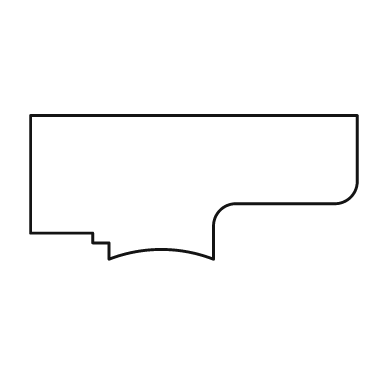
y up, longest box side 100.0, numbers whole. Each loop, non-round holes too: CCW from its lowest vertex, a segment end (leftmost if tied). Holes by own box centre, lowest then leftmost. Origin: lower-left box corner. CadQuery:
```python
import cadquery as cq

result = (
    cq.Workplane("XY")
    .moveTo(24.0, 0.0)
    .threePointArc((40.0, 3.0), (56.0, 0.0))
    .lineTo(56.0, 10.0)
    .threePointArc((58.0, 15.0), (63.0, 17.0))
    .lineTo(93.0, 17.0)
    .threePointArc((98.0, 19.0), (100.0, 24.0))
    .lineTo(100.0, 44.0)
    .lineTo(0.0, 44.0)
    .lineTo(0.0, 8.0)
    .lineTo(19.0, 8.0)
    .lineTo(19.0, 5.0)
    .lineTo(24.0, 5.0)
    .close()
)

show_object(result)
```